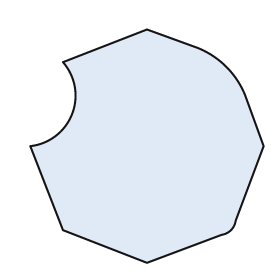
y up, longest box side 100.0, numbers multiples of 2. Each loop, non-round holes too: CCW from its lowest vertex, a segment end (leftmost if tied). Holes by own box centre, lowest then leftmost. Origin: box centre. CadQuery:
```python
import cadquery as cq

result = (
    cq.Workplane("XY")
    .moveTo(0.0, -50.0)
    .lineTo(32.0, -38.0)
    .threePointArc((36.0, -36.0), (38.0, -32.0))
    .lineTo(50.0, 0.0)
    .lineTo(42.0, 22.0)
    .threePointArc((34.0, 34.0), (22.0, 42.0))
    .lineTo(0.0, 50.0)
    .lineTo(-36.0, 36.0)
    .threePointArc((-32.0, 14.0), (-50.0, 0.0))
    .lineTo(-36.0, -36.0)
    .close()
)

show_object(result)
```